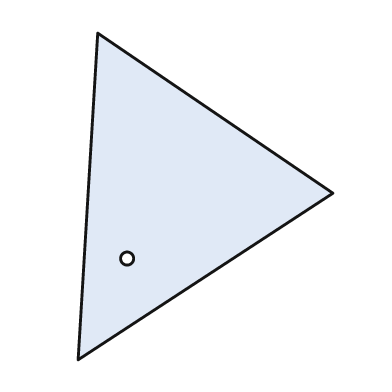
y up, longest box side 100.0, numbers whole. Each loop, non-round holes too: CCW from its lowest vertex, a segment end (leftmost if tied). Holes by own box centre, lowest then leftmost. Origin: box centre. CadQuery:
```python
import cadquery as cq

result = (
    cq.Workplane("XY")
    .moveTo(-39.0, -50.0)
    .lineTo(39.0, 1.0)
    .lineTo(-33.0, 50.0)
    .close()
    .moveTo(-24.0, -19.0)
    .circle(2.0)
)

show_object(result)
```